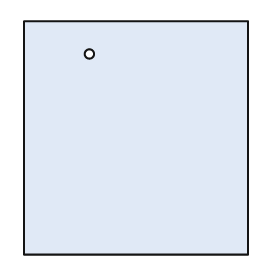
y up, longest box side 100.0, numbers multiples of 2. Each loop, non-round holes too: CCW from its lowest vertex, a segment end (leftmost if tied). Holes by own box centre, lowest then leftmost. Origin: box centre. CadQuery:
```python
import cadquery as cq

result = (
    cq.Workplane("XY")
    .moveTo(-48.0, -50.0)
    .lineTo(48.0, -50.0)
    .lineTo(48.0, 50.0)
    .lineTo(-48.0, 50.0)
    .close()
    .moveTo(-20.0, 36.0)
    .circle(2.0)
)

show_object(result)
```